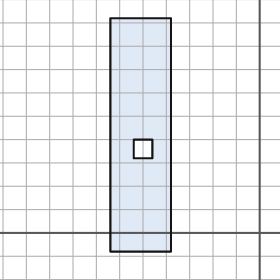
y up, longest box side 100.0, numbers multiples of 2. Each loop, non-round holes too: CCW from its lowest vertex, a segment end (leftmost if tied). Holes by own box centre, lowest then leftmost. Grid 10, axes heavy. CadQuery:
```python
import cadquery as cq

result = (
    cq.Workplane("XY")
    .moveTo(-64.0, -8.0)
    .lineTo(-38.0, -8.0)
    .lineTo(-38.0, 92.0)
    .lineTo(-64.0, 92.0)
    .close()
    .moveTo(-54.0, 32.0)
    .lineTo(-46.0, 32.0)
    .lineTo(-46.0, 40.0)
    .lineTo(-54.0, 40.0)
    .close()
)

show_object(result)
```